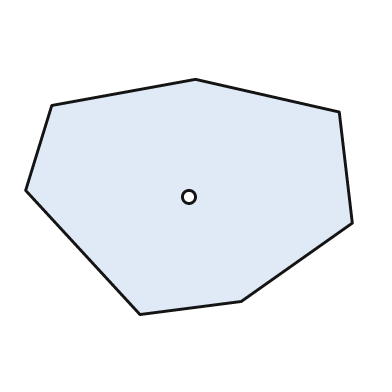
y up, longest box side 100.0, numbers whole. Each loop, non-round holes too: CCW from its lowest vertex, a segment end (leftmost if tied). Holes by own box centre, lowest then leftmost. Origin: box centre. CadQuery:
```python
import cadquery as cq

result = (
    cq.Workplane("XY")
    .moveTo(-15.0, -36.0)
    .lineTo(16.0, -32.0)
    .lineTo(50.0, -8.0)
    .lineTo(46.0, 26.0)
    .lineTo(2.0, 36.0)
    .lineTo(-42.0, 28.0)
    .lineTo(-50.0, 2.0)
    .close()
    .moveTo(0.0, 0.0)
    .circle(2.0)
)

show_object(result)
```